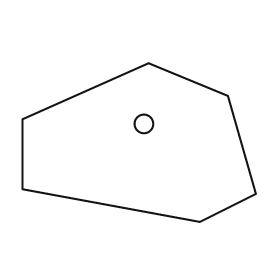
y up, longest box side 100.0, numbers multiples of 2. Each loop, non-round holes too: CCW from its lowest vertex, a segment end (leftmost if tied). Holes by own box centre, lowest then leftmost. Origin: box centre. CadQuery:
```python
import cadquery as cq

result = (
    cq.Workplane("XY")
    .moveTo(26.0, -34.0)
    .lineTo(50.0, -22.0)
    .lineTo(38.0, 20.0)
    .lineTo(4.0, 34.0)
    .lineTo(-50.0, 10.0)
    .lineTo(-50.0, -20.0)
    .close()
    .moveTo(2.0, 8.0)
    .circle(4.0)
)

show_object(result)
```